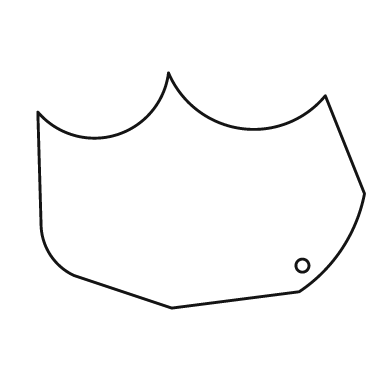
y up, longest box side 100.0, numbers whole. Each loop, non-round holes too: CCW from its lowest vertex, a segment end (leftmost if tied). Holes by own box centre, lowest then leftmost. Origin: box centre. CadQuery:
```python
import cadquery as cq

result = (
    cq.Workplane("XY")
    .moveTo(-9.0, -36.0)
    .lineTo(30.0, -31.0)
    .threePointArc((43.0, -18.0), (50.0, -1.0))
    .lineTo(38.0, 29.0)
    .threePointArc((12.0, 19.0), (-10.0, 36.0))
    .threePointArc((-26.0, 17.0), (-50.0, 24.0))
    .lineTo(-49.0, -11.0)
    .threePointArc((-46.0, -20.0), (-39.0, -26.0))
    .close()
    .moveTo(31.0, -23.0)
    .circle(2.0)
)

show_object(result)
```